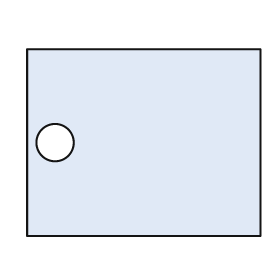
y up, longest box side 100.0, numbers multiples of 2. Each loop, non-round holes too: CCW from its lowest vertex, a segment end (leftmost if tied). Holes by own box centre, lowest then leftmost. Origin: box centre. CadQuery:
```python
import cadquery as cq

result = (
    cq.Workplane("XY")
    .moveTo(-50.0, -40.0)
    .lineTo(50.0, -40.0)
    .lineTo(50.0, 40.0)
    .lineTo(-50.0, 40.0)
    .close()
    .moveTo(-38.0, 0.0)
    .circle(8.0)
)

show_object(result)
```